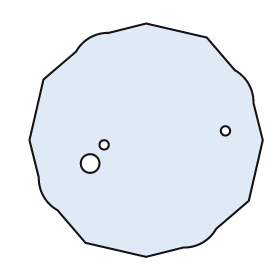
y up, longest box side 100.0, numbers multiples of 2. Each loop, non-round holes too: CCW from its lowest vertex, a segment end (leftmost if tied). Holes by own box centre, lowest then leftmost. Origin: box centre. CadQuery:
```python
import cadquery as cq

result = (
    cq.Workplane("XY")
    .moveTo(0.0, -50.0)
    .lineTo(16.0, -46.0)
    .threePointArc((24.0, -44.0), (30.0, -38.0))
    .lineTo(44.0, -26.0)
    .lineTo(50.0, 0.0)
    .lineTo(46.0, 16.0)
    .threePointArc((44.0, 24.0), (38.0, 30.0))
    .lineTo(26.0, 44.0)
    .lineTo(0.0, 50.0)
    .lineTo(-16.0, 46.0)
    .threePointArc((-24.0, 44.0), (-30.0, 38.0))
    .lineTo(-44.0, 26.0)
    .lineTo(-50.0, 0.0)
    .lineTo(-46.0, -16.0)
    .threePointArc((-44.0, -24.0), (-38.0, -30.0))
    .lineTo(-26.0, -44.0)
    .close()
    .moveTo(-24.0, -10.0)
    .circle(4.0)
    .moveTo(-18.0, -2.0)
    .circle(2.0)
    .moveTo(34.0, 4.0)
    .circle(2.0)
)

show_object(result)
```